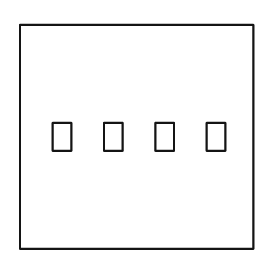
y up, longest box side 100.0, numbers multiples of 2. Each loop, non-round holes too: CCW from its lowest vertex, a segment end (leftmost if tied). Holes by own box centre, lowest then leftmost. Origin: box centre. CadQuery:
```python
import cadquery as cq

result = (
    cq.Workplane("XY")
    .moveTo(-50.0, -48.0)
    .lineTo(50.0, -48.0)
    .lineTo(50.0, 48.0)
    .lineTo(-50.0, 48.0)
    .close()
    .moveTo(-36.0, -6.0)
    .lineTo(-28.0, -6.0)
    .lineTo(-28.0, 6.0)
    .lineTo(-36.0, 6.0)
    .close()
    .moveTo(-14.0, -6.0)
    .lineTo(-6.0, -6.0)
    .lineTo(-6.0, 6.0)
    .lineTo(-14.0, 6.0)
    .close()
    .moveTo(8.0, -6.0)
    .lineTo(16.0, -6.0)
    .lineTo(16.0, 6.0)
    .lineTo(8.0, 6.0)
    .close()
    .moveTo(30.0, -6.0)
    .lineTo(38.0, -6.0)
    .lineTo(38.0, 6.0)
    .lineTo(30.0, 6.0)
    .close()
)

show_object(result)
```